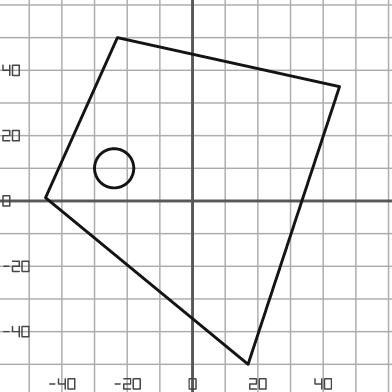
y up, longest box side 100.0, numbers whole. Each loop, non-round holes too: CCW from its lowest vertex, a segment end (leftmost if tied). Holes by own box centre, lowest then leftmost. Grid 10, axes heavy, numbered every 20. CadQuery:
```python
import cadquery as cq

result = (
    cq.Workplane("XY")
    .moveTo(17.0, -50.0)
    .lineTo(45.0, 35.0)
    .lineTo(-23.0, 50.0)
    .lineTo(-45.0, 1.0)
    .close()
    .moveTo(-24.0, 10.0)
    .circle(6.0)
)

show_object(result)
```